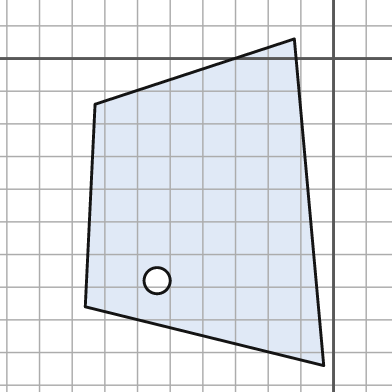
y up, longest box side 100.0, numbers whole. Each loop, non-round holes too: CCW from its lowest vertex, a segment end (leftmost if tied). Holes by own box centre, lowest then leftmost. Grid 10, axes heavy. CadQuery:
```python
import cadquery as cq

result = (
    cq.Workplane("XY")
    .moveTo(-3.0, -94.0)
    .lineTo(-12.0, 6.0)
    .lineTo(-73.0, -14.0)
    .lineTo(-76.0, -76.0)
    .close()
    .moveTo(-54.0, -68.0)
    .circle(4.0)
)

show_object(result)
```